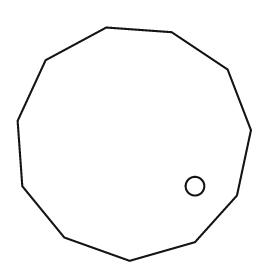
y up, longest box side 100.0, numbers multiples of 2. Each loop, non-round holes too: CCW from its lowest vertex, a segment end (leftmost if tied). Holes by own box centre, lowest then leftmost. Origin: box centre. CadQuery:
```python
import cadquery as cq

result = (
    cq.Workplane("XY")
    .moveTo(-2.0, -50.0)
    .lineTo(26.0, -42.0)
    .lineTo(44.0, -22.0)
    .lineTo(50.0, 6.0)
    .lineTo(40.0, 32.0)
    .lineTo(16.0, 48.0)
    .lineTo(-12.0, 50.0)
    .lineTo(-38.0, 36.0)
    .lineTo(-50.0, 10.0)
    .lineTo(-48.0, -18.0)
    .lineTo(-30.0, -40.0)
    .close()
    .moveTo(26.0, -18.0)
    .circle(4.0)
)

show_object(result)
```